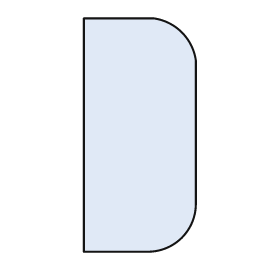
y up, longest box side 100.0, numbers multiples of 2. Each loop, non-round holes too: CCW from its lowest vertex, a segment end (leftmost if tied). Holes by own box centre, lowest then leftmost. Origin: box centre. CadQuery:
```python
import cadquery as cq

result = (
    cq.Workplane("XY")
    .moveTo(-24.0, -50.0)
    .lineTo(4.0, -50.0)
    .threePointArc((18.0, -44.0), (24.0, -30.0))
    .lineTo(24.0, 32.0)
    .threePointArc((18.0, 44.0), (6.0, 50.0))
    .lineTo(-24.0, 50.0)
    .close()
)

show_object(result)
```